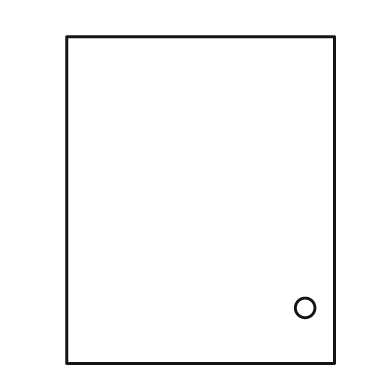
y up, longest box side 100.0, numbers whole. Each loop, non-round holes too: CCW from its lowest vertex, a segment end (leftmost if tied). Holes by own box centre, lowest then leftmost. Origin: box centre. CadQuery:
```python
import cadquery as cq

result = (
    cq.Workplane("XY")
    .moveTo(-41.0, -50.0)
    .lineTo(41.0, -50.0)
    .lineTo(41.0, 50.0)
    .lineTo(-41.0, 50.0)
    .close()
    .moveTo(32.0, -33.0)
    .circle(3.0)
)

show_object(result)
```